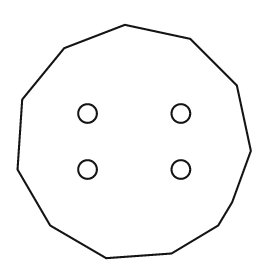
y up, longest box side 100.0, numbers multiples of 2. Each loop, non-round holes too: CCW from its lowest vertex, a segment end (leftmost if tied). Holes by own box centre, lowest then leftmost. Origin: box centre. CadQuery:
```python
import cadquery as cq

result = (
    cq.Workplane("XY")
    .moveTo(-12.0, -50.0)
    .lineTo(16.0, -48.0)
    .lineTo(36.0, -36.0)
    .lineTo(42.0, -26.0)
    .lineTo(50.0, -4.0)
    .lineTo(44.0, 24.0)
    .lineTo(24.0, 44.0)
    .lineTo(-4.0, 50.0)
    .lineTo(-30.0, 40.0)
    .lineTo(-48.0, 18.0)
    .lineTo(-50.0, -12.0)
    .lineTo(-36.0, -36.0)
    .close()
    .moveTo(-20.0, -12.0)
    .circle(4.0)
    .moveTo(20.0, -12.0)
    .circle(4.0)
    .moveTo(-20.0, 12.0)
    .circle(4.0)
    .moveTo(20.0, 12.0)
    .circle(4.0)
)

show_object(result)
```